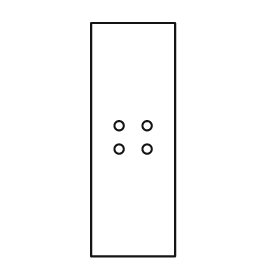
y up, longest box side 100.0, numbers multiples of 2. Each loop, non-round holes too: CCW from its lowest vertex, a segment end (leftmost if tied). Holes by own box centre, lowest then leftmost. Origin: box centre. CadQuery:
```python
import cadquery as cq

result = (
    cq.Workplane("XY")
    .moveTo(-18.0, -50.0)
    .lineTo(18.0, -50.0)
    .lineTo(18.0, 50.0)
    .lineTo(-18.0, 50.0)
    .close()
    .moveTo(-6.0, -4.0)
    .circle(2.0)
    .moveTo(6.0, -4.0)
    .circle(2.0)
    .moveTo(-6.0, 6.0)
    .circle(2.0)
    .moveTo(6.0, 6.0)
    .circle(2.0)
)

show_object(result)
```